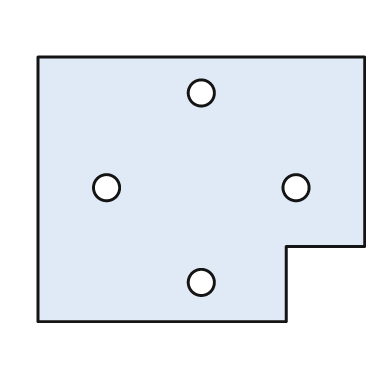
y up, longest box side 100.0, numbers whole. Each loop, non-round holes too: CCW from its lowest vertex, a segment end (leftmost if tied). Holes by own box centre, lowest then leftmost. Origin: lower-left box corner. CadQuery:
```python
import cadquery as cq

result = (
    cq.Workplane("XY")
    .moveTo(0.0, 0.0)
    .lineTo(76.0, 0.0)
    .lineTo(76.0, 23.0)
    .lineTo(100.0, 23.0)
    .lineTo(100.0, 81.0)
    .lineTo(0.0, 81.0)
    .close()
    .moveTo(50.0, 12.0)
    .circle(4.0)
    .moveTo(21.0, 41.0)
    .circle(4.0)
    .moveTo(79.0, 41.0)
    .circle(4.0)
    .moveTo(50.0, 70.0)
    .circle(4.0)
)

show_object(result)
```